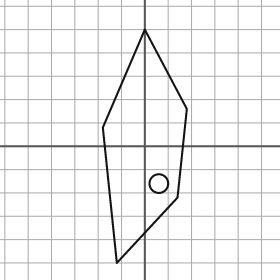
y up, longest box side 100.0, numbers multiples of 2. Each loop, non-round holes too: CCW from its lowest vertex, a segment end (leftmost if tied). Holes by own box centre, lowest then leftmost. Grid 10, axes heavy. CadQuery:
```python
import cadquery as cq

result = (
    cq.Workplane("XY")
    .moveTo(-12.0, -50.0)
    .lineTo(14.0, -22.0)
    .lineTo(18.0, 16.0)
    .lineTo(0.0, 50.0)
    .lineTo(-18.0, 8.0)
    .close()
    .moveTo(6.0, -16.0)
    .circle(4.0)
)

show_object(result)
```